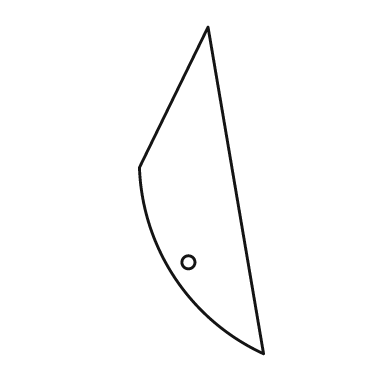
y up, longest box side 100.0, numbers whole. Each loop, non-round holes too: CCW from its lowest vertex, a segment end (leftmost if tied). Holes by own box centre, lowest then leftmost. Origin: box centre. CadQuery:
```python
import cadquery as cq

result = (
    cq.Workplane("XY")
    .moveTo(19.0, -50.0)
    .lineTo(2.0, 50.0)
    .lineTo(-19.0, 7.0)
    .threePointArc((-8.0, -27.0), (19.0, -50.0))
    .close()
    .moveTo(-4.0, -22.0)
    .circle(2.0)
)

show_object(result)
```